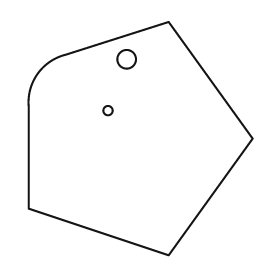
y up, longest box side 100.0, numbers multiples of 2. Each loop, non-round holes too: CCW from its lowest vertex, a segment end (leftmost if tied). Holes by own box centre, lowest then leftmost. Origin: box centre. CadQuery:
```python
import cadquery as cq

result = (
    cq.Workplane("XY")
    .moveTo(12.0, -50.0)
    .lineTo(48.0, 0.0)
    .lineTo(12.0, 50.0)
    .lineTo(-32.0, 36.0)
    .threePointArc((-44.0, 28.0), (-48.0, 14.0))
    .lineTo(-48.0, -30.0)
    .close()
    .moveTo(-14.0, 12.0)
    .circle(2.0)
    .moveTo(-6.0, 34.0)
    .circle(4.0)
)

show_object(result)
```